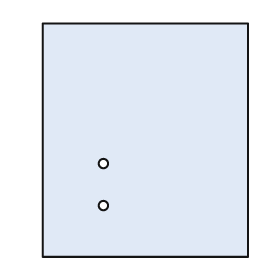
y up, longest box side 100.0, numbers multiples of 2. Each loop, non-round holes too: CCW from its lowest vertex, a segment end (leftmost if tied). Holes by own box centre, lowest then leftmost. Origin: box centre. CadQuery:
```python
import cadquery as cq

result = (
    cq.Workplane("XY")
    .moveTo(-44.0, -50.0)
    .lineTo(44.0, -50.0)
    .lineTo(44.0, 50.0)
    .lineTo(-44.0, 50.0)
    .close()
    .moveTo(-18.0, -28.0)
    .circle(2.0)
    .moveTo(-18.0, -10.0)
    .circle(2.0)
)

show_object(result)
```